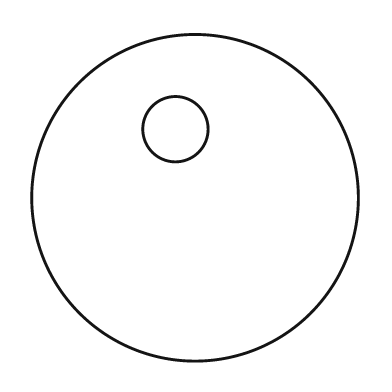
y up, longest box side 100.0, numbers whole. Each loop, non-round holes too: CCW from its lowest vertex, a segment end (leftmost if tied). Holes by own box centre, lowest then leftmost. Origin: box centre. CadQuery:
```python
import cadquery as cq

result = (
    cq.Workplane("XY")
    .moveTo(0.0, 0.0)
    .circle(50.0)
    .moveTo(-6.0, 21.0)
    .circle(10.0)
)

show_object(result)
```